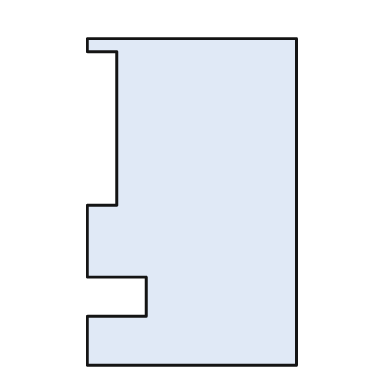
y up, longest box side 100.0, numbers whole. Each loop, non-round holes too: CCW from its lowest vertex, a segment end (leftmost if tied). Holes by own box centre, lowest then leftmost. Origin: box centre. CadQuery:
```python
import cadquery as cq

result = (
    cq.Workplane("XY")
    .moveTo(-32.0, -50.0)
    .lineTo(32.0, -50.0)
    .lineTo(32.0, 50.0)
    .lineTo(-32.0, 50.0)
    .lineTo(-32.0, 46.0)
    .lineTo(-23.0, 46.0)
    .lineTo(-23.0, -1.0)
    .lineTo(-32.0, -1.0)
    .lineTo(-32.0, -23.0)
    .lineTo(-14.0, -23.0)
    .lineTo(-14.0, -35.0)
    .lineTo(-32.0, -35.0)
    .close()
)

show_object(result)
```